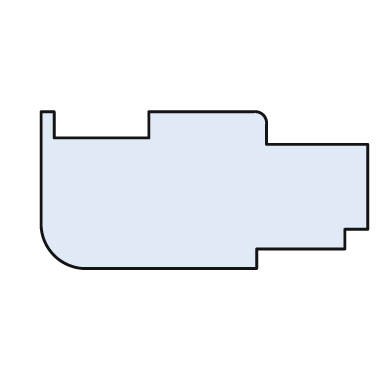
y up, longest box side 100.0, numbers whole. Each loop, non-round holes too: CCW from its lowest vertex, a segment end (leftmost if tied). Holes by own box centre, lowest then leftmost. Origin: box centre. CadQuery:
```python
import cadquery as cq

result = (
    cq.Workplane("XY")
    .moveTo(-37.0, -24.0)
    .lineTo(16.0, -24.0)
    .lineTo(16.0, -18.0)
    .lineTo(43.0, -18.0)
    .lineTo(43.0, -12.0)
    .lineTo(50.0, -12.0)
    .lineTo(50.0, 14.0)
    .lineTo(19.0, 14.0)
    .lineTo(19.0, 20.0)
    .threePointArc((18.0, 23.0), (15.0, 24.0))
    .lineTo(-17.0, 24.0)
    .lineTo(-17.0, 16.0)
    .lineTo(-46.0, 16.0)
    .lineTo(-46.0, 24.0)
    .lineTo(-50.0, 24.0)
    .lineTo(-50.0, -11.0)
    .threePointArc((-46.0, -20.0), (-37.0, -24.0))
    .close()
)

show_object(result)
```